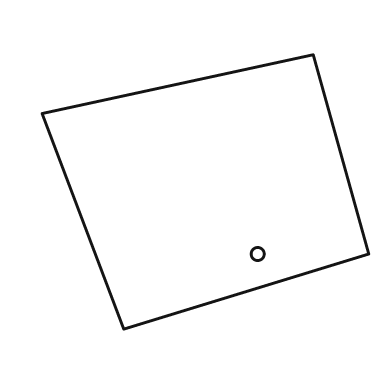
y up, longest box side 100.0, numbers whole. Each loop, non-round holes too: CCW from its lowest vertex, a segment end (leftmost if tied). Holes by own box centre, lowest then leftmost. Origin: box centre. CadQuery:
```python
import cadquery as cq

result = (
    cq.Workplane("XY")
    .moveTo(-25.0, -42.0)
    .lineTo(50.0, -19.0)
    .lineTo(33.0, 42.0)
    .lineTo(-50.0, 24.0)
    .close()
    .moveTo(16.0, -19.0)
    .circle(2.0)
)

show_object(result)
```